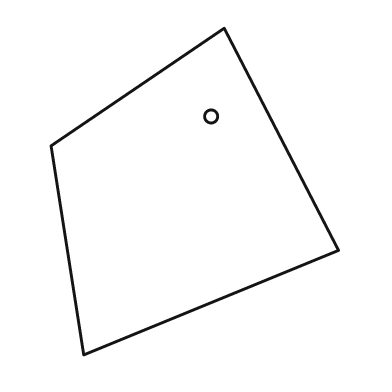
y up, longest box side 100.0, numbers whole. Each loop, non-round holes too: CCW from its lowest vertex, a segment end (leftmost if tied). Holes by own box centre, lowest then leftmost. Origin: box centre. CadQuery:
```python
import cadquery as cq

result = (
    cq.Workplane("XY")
    .moveTo(-34.0, -50.0)
    .lineTo(44.0, -18.0)
    .lineTo(9.0, 50.0)
    .lineTo(-44.0, 14.0)
    .close()
    .moveTo(5.0, 23.0)
    .circle(2.0)
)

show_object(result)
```